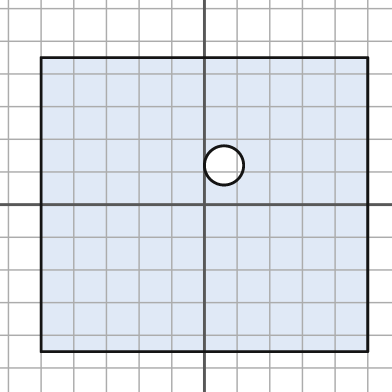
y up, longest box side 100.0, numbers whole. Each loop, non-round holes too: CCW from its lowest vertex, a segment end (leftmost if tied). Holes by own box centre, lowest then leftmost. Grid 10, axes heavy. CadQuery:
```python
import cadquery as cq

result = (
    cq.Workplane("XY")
    .moveTo(-50.0, -45.0)
    .lineTo(50.0, -45.0)
    .lineTo(50.0, 45.0)
    .lineTo(-50.0, 45.0)
    .close()
    .moveTo(6.0, 12.0)
    .circle(6.0)
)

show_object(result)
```